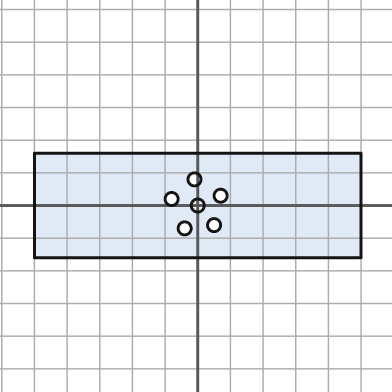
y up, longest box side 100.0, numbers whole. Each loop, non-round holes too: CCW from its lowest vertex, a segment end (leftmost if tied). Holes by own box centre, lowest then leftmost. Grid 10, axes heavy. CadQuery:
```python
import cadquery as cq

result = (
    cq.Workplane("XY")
    .moveTo(-50.0, -16.0)
    .lineTo(50.0, -16.0)
    .lineTo(50.0, 16.0)
    .lineTo(-50.0, 16.0)
    .close()
    .moveTo(-4.0, -7.0)
    .circle(2.0)
    .moveTo(5.0, -6.0)
    .circle(2.0)
    .moveTo(0.0, 0.0)
    .circle(2.0)
    .moveTo(-8.0, 2.0)
    .circle(2.0)
    .moveTo(7.0, 3.0)
    .circle(2.0)
    .moveTo(-1.0, 8.0)
    .circle(2.0)
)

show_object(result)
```